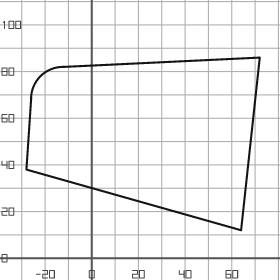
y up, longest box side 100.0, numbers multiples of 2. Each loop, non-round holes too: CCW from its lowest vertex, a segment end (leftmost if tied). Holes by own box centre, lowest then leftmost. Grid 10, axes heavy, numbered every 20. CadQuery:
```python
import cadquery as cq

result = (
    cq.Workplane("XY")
    .moveTo(64.0, 12.0)
    .lineTo(72.0, 86.0)
    .lineTo(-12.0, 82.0)
    .threePointArc((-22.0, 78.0), (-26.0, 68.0))
    .lineTo(-28.0, 38.0)
    .close()
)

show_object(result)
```